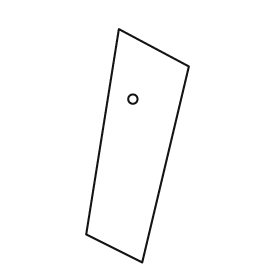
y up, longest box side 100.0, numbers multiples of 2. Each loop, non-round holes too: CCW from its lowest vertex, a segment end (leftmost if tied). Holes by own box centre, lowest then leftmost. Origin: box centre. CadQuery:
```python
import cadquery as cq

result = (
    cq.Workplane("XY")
    .moveTo(2.0, -50.0)
    .lineTo(22.0, 34.0)
    .lineTo(-8.0, 50.0)
    .lineTo(-22.0, -38.0)
    .close()
    .moveTo(-2.0, 20.0)
    .circle(2.0)
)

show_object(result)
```